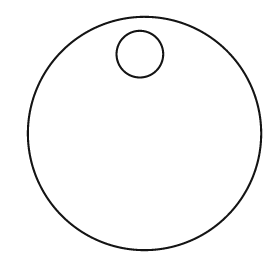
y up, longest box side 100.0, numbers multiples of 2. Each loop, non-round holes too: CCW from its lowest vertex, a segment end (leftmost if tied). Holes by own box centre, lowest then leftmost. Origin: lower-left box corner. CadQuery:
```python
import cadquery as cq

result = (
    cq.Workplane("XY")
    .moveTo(50.0, 50.0)
    .circle(50.0)
    .moveTo(48.0, 84.0)
    .circle(10.0)
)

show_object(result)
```